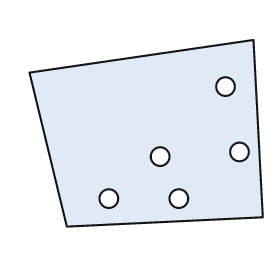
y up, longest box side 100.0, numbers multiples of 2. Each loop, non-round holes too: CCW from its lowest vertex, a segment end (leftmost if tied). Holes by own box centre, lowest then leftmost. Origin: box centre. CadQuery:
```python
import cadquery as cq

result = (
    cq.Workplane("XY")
    .moveTo(-34.0, -40.0)
    .lineTo(50.0, -36.0)
    .lineTo(46.0, 40.0)
    .lineTo(-50.0, 26.0)
    .close()
    .moveTo(-16.0, -28.0)
    .circle(4.0)
    .moveTo(14.0, -28.0)
    .circle(4.0)
    .moveTo(6.0, -10.0)
    .circle(4.0)
    .moveTo(40.0, -8.0)
    .circle(4.0)
    .moveTo(34.0, 20.0)
    .circle(4.0)
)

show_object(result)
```